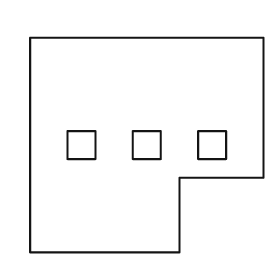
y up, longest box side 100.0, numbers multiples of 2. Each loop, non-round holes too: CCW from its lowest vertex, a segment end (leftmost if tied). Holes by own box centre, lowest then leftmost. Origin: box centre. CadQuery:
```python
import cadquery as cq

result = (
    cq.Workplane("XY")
    .moveTo(-50.0, -46.0)
    .lineTo(14.0, -46.0)
    .lineTo(14.0, -14.0)
    .lineTo(50.0, -14.0)
    .lineTo(50.0, 46.0)
    .lineTo(-50.0, 46.0)
    .close()
    .moveTo(-34.0, -6.0)
    .lineTo(-22.0, -6.0)
    .lineTo(-22.0, 6.0)
    .lineTo(-34.0, 6.0)
    .close()
    .moveTo(-6.0, -6.0)
    .lineTo(6.0, -6.0)
    .lineTo(6.0, 6.0)
    .lineTo(-6.0, 6.0)
    .close()
    .moveTo(22.0, -6.0)
    .lineTo(34.0, -6.0)
    .lineTo(34.0, 6.0)
    .lineTo(22.0, 6.0)
    .close()
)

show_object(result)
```